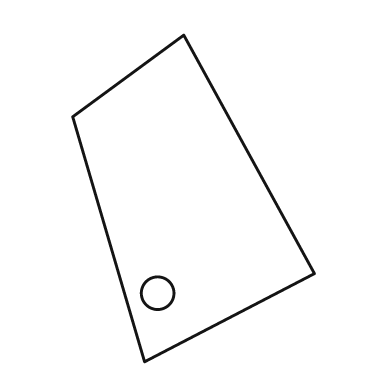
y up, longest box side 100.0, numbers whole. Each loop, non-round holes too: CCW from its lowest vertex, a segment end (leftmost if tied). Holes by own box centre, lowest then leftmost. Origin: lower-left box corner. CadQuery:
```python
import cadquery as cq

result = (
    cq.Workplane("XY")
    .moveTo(22.0, 0.0)
    .lineTo(74.0, 27.0)
    .lineTo(34.0, 100.0)
    .lineTo(0.0, 75.0)
    .close()
    .moveTo(26.0, 21.0)
    .circle(5.0)
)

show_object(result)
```